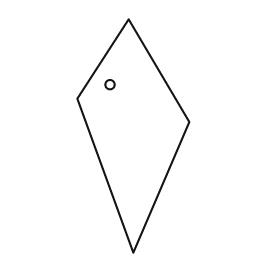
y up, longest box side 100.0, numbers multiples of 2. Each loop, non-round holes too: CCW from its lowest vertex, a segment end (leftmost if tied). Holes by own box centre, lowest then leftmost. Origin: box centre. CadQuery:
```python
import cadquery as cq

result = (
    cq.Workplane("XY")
    .moveTo(0.0, -50.0)
    .lineTo(24.0, 6.0)
    .lineTo(-2.0, 50.0)
    .lineTo(-24.0, 16.0)
    .close()
    .moveTo(-10.0, 22.0)
    .circle(2.0)
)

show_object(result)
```